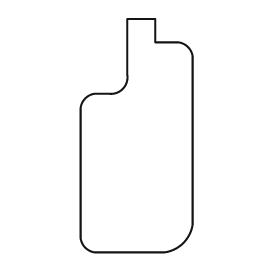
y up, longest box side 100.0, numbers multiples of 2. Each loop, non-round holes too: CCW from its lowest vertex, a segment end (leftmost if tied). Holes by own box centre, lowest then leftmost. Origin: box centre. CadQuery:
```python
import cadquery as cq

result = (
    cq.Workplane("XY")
    .moveTo(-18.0, -50.0)
    .lineTo(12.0, -50.0)
    .threePointArc((20.0, -46.0), (24.0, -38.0))
    .lineTo(24.0, 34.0)
    .threePointArc((22.0, 38.0), (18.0, 40.0))
    .lineTo(8.0, 40.0)
    .lineTo(8.0, 50.0)
    .lineTo(-4.0, 50.0)
    .lineTo(-4.0, 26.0)
    .threePointArc((-6.0, 20.0), (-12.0, 18.0))
    .lineTo(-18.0, 18.0)
    .threePointArc((-22.0, 16.0), (-24.0, 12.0))
    .lineTo(-24.0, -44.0)
    .threePointArc((-22.0, -48.0), (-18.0, -50.0))
    .close()
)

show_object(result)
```